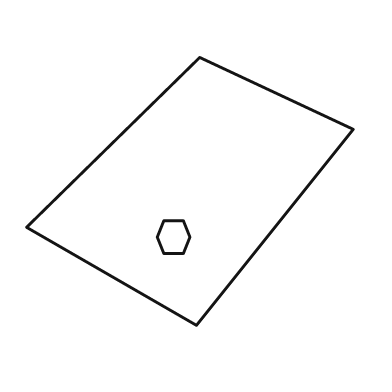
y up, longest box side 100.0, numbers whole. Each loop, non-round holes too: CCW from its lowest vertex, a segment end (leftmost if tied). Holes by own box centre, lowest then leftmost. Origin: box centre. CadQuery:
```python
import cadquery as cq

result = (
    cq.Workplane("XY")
    .moveTo(2.0, -41.0)
    .lineTo(50.0, 19.0)
    .lineTo(3.0, 41.0)
    .lineTo(-50.0, -11.0)
    .close()
    .moveTo(-8.0, -19.0)
    .lineTo(-2.0, -19.0)
    .lineTo(0.0, -14.0)
    .lineTo(-2.0, -9.0)
    .lineTo(-8.0, -9.0)
    .lineTo(-10.0, -14.0)
    .close()
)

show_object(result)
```